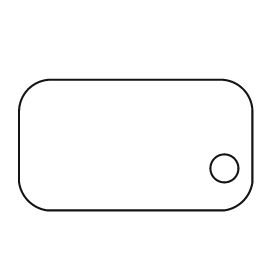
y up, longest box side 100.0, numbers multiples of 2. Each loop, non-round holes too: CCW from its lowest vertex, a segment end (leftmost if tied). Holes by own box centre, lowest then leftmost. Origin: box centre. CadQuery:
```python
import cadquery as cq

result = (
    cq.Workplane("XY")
    .moveTo(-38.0, -28.0)
    .lineTo(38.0, -28.0)
    .threePointArc((46.0, -24.0), (50.0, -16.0))
    .lineTo(50.0, 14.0)
    .threePointArc((46.0, 24.0), (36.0, 28.0))
    .lineTo(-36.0, 28.0)
    .threePointArc((-46.0, 24.0), (-50.0, 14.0))
    .lineTo(-50.0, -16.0)
    .threePointArc((-46.0, -24.0), (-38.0, -28.0))
    .close()
    .moveTo(38.0, -10.0)
    .circle(6.0)
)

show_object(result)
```